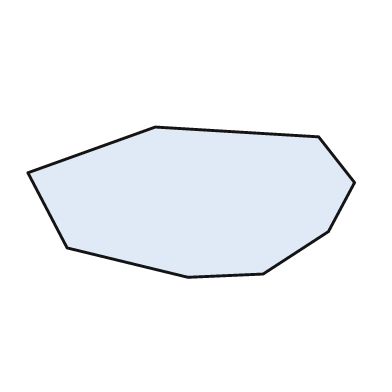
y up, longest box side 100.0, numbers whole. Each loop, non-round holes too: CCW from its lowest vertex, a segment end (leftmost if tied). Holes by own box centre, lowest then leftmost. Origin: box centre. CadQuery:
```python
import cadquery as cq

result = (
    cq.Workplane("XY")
    .moveTo(-1.0, -23.0)
    .lineTo(22.0, -22.0)
    .lineTo(42.0, -9.0)
    .lineTo(50.0, 6.0)
    .lineTo(39.0, 20.0)
    .lineTo(-11.0, 23.0)
    .lineTo(-50.0, 9.0)
    .lineTo(-38.0, -14.0)
    .close()
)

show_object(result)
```